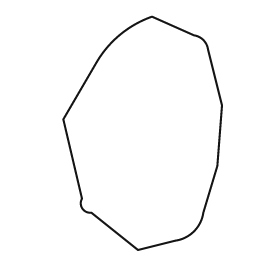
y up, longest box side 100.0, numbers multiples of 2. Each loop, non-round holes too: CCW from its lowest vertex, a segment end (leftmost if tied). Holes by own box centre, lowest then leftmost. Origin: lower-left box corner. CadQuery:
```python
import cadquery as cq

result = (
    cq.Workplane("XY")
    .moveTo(32.0, 0.0)
    .lineTo(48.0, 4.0)
    .threePointArc((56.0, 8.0), (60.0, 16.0))
    .lineTo(66.0, 36.0)
    .lineTo(68.0, 62.0)
    .lineTo(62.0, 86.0)
    .threePointArc((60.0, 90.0), (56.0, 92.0))
    .lineTo(38.0, 100.0)
    .threePointArc((24.0, 92.0), (14.0, 80.0))
    .lineTo(0.0, 56.0)
    .lineTo(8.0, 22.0)
    .threePointArc((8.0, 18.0), (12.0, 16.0))
    .close()
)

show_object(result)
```